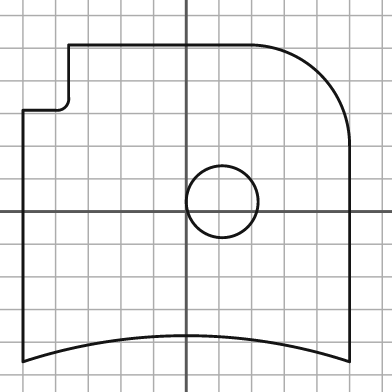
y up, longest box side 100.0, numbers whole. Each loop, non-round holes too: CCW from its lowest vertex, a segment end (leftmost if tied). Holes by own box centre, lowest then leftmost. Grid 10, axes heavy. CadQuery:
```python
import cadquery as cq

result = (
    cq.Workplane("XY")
    .moveTo(-50.0, -46.0)
    .threePointArc((0.0, -38.0), (50.0, -46.0))
    .lineTo(50.0, 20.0)
    .threePointArc((41.0, 42.0), (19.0, 51.0))
    .lineTo(-36.0, 51.0)
    .lineTo(-36.0, 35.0)
    .threePointArc((-37.0, 32.0), (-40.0, 31.0))
    .lineTo(-50.0, 31.0)
    .close()
    .moveTo(11.0, 3.0)
    .circle(11.0)
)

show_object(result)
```